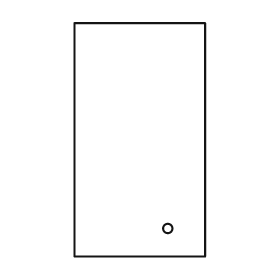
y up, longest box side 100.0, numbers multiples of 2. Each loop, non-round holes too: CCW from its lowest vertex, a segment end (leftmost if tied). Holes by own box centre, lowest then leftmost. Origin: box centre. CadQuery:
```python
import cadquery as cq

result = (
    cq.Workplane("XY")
    .moveTo(-28.0, -50.0)
    .lineTo(28.0, -50.0)
    .lineTo(28.0, 50.0)
    .lineTo(-28.0, 50.0)
    .close()
    .moveTo(12.0, -38.0)
    .circle(2.0)
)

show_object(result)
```